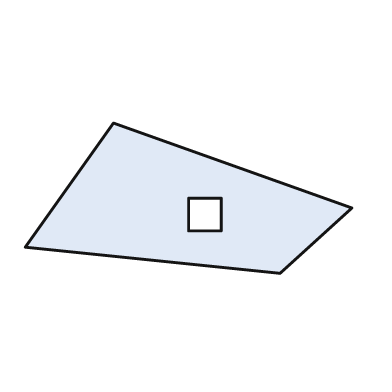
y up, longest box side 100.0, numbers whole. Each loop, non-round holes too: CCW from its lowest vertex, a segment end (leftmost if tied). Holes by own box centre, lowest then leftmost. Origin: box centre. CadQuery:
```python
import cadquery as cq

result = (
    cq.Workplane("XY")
    .moveTo(28.0, -23.0)
    .lineTo(50.0, -3.0)
    .lineTo(-23.0, 23.0)
    .lineTo(-50.0, -15.0)
    .close()
    .moveTo(0.0, -10.0)
    .lineTo(10.0, -10.0)
    .lineTo(10.0, 0.0)
    .lineTo(0.0, 0.0)
    .close()
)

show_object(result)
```